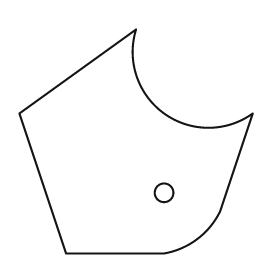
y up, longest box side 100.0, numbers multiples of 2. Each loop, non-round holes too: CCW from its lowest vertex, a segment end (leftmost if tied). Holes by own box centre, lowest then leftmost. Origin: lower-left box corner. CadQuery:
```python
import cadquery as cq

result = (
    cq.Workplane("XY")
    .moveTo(20.0, 0.0)
    .lineTo(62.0, 0.0)
    .threePointArc((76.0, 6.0), (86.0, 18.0))
    .lineTo(100.0, 60.0)
    .threePointArc((62.0, 60.0), (50.0, 96.0))
    .lineTo(0.0, 60.0)
    .close()
    .moveTo(62.0, 26.0)
    .circle(4.0)
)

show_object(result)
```